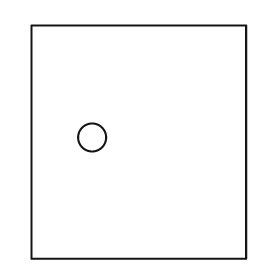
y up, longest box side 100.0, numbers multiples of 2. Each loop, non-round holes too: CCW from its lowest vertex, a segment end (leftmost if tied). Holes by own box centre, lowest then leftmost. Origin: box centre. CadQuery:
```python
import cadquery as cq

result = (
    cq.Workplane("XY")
    .moveTo(-46.0, -50.0)
    .lineTo(46.0, -50.0)
    .lineTo(46.0, 50.0)
    .lineTo(-46.0, 50.0)
    .close()
    .moveTo(-20.0, 2.0)
    .circle(6.0)
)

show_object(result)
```